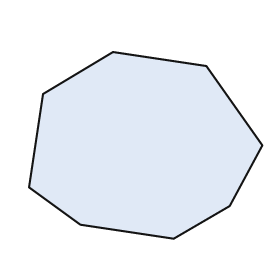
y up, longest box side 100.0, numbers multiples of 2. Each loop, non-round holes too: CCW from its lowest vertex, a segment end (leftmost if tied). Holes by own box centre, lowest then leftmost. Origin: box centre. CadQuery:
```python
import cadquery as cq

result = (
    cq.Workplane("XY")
    .moveTo(12.0, -40.0)
    .lineTo(36.0, -26.0)
    .lineTo(50.0, 0.0)
    .lineTo(26.0, 34.0)
    .lineTo(-14.0, 40.0)
    .lineTo(-44.0, 22.0)
    .lineTo(-50.0, -18.0)
    .lineTo(-28.0, -34.0)
    .close()
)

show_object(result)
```